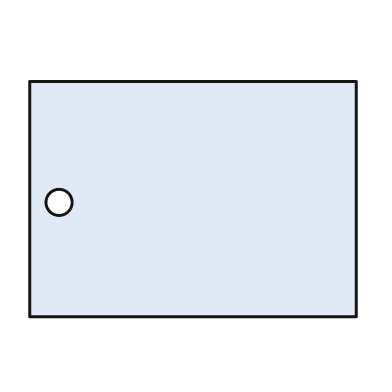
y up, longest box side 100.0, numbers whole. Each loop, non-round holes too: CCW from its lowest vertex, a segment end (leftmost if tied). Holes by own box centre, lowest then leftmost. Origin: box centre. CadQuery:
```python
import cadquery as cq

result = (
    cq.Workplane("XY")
    .moveTo(-50.0, -36.0)
    .lineTo(50.0, -36.0)
    .lineTo(50.0, 36.0)
    .lineTo(-50.0, 36.0)
    .close()
    .moveTo(-41.0, -1.0)
    .circle(4.0)
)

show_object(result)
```